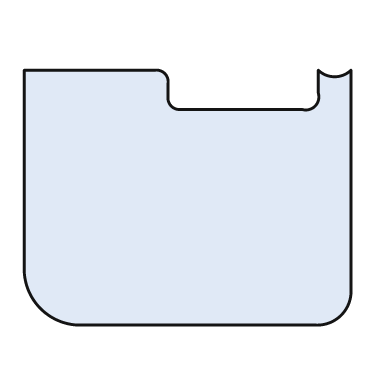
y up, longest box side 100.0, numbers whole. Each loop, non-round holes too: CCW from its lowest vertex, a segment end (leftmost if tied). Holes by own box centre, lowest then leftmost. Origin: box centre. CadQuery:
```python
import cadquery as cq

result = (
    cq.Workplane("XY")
    .moveTo(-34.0, -39.0)
    .lineTo(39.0, -39.0)
    .threePointArc((47.0, -36.0), (50.0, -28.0))
    .lineTo(50.0, 39.0)
    .threePointArc((45.0, 37.0), (40.0, 39.0))
    .lineTo(40.0, 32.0)
    .threePointArc((39.0, 28.0), (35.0, 27.0))
    .lineTo(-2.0, 27.0)
    .threePointArc((-5.0, 28.0), (-6.0, 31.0))
    .lineTo(-6.0, 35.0)
    .threePointArc((-7.0, 38.0), (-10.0, 39.0))
    .lineTo(-50.0, 39.0)
    .lineTo(-50.0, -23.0)
    .threePointArc((-45.0, -34.0), (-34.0, -39.0))
    .close()
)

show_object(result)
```